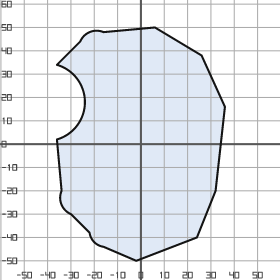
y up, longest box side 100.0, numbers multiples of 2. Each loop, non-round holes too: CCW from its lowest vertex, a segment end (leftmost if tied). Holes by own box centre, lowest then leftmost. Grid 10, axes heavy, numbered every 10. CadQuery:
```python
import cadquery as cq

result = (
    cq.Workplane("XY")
    .moveTo(-2.0, -50.0)
    .lineTo(24.0, -40.0)
    .lineTo(32.0, -20.0)
    .lineTo(36.0, 16.0)
    .lineTo(26.0, 38.0)
    .lineTo(6.0, 50.0)
    .lineTo(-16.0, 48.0)
    .threePointArc((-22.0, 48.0), (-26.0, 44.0))
    .lineTo(-36.0, 34.0)
    .threePointArc((-24.0, 18.0), (-36.0, 2.0))
    .lineTo(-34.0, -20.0)
    .threePointArc((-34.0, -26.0), (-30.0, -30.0))
    .lineTo(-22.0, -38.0)
    .threePointArc((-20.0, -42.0), (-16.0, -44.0))
    .close()
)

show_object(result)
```